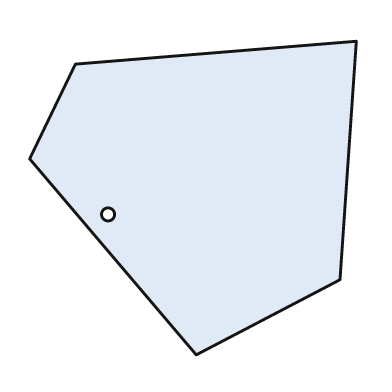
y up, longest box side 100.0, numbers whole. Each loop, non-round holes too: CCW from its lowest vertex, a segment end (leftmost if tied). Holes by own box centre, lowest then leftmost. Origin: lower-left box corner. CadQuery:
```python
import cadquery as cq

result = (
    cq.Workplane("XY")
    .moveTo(51.0, 0.0)
    .lineTo(95.0, 23.0)
    .lineTo(100.0, 96.0)
    .lineTo(14.0, 89.0)
    .lineTo(0.0, 60.0)
    .close()
    .moveTo(24.0, 43.0)
    .circle(2.0)
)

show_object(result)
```